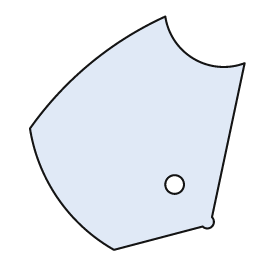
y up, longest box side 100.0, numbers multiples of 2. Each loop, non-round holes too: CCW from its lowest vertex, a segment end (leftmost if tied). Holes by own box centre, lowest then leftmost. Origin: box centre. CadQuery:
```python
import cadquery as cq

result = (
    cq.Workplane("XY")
    .moveTo(-10.0, -50.0)
    .lineTo(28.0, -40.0)
    .threePointArc((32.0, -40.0), (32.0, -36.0))
    .lineTo(46.0, 30.0)
    .threePointArc((24.0, 32.0), (12.0, 50.0))
    .threePointArc((-20.0, 30.0), (-46.0, 2.0))
    .threePointArc((-34.0, -28.0), (-10.0, -50.0))
    .close()
    .moveTo(16.0, -22.0)
    .circle(4.0)
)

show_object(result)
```